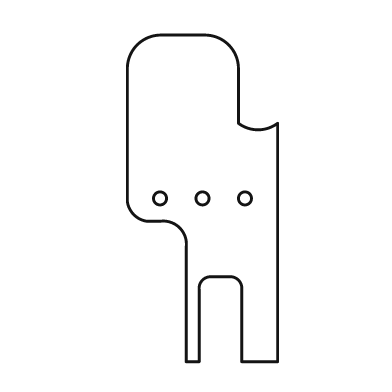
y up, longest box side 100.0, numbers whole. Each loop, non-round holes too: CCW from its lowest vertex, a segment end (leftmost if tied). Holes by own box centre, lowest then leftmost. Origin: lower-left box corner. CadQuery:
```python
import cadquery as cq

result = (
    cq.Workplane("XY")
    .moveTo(18.0, 0.0)
    .lineTo(22.0, 0.0)
    .lineTo(22.0, 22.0)
    .threePointArc((23.0, 25.0), (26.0, 26.0))
    .lineTo(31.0, 26.0)
    .threePointArc((34.0, 25.0), (35.0, 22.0))
    .lineTo(35.0, 0.0)
    .lineTo(46.0, 0.0)
    .lineTo(46.0, 73.0)
    .threePointArc((40.0, 71.0), (34.0, 73.0))
    .lineTo(34.0, 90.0)
    .threePointArc((31.0, 97.0), (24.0, 100.0))
    .lineTo(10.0, 100.0)
    .threePointArc((3.0, 97.0), (0.0, 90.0))
    .lineTo(0.0, 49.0)
    .threePointArc((2.0, 45.0), (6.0, 43.0))
    .lineTo(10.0, 43.0)
    .threePointArc((16.0, 41.0), (18.0, 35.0))
    .close()
    .moveTo(10.0, 50.0)
    .circle(2.0)
    .moveTo(23.0, 50.0)
    .circle(2.0)
    .moveTo(36.0, 50.0)
    .circle(2.0)
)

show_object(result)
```